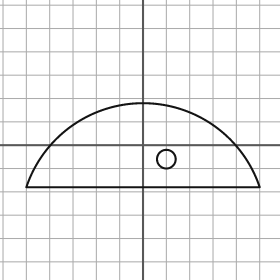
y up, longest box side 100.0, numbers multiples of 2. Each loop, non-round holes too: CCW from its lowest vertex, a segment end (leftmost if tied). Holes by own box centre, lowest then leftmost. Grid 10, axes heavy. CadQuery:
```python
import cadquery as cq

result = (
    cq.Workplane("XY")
    .moveTo(-50.0, -18.0)
    .lineTo(50.0, -18.0)
    .threePointArc((0.0, 18.0), (-50.0, -18.0))
    .close()
    .moveTo(10.0, -6.0)
    .circle(4.0)
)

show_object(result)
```